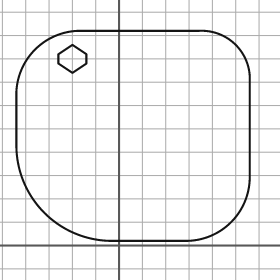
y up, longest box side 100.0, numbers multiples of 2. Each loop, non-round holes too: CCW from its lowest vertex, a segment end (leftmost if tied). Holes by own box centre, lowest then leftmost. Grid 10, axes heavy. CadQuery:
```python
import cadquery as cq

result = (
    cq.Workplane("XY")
    .moveTo(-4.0, 2.0)
    .lineTo(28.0, 2.0)
    .threePointArc((48.0, 10.0), (56.0, 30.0))
    .lineTo(56.0, 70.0)
    .threePointArc((50.0, 86.0), (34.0, 92.0))
    .lineTo(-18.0, 92.0)
    .threePointArc((-36.0, 84.0), (-44.0, 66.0))
    .lineTo(-44.0, 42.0)
    .threePointArc((-32.0, 14.0), (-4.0, 2.0))
    .close()
    .moveTo(-20.0, 74.0)
    .lineTo(-14.0, 78.0)
    .lineTo(-14.0, 82.0)
    .lineTo(-20.0, 86.0)
    .lineTo(-26.0, 82.0)
    .lineTo(-26.0, 78.0)
    .close()
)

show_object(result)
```